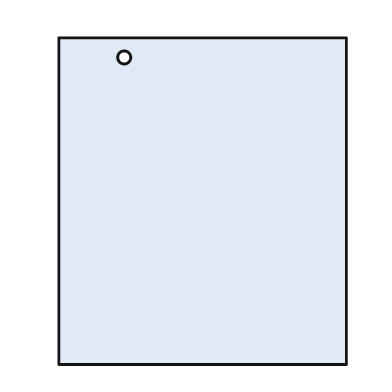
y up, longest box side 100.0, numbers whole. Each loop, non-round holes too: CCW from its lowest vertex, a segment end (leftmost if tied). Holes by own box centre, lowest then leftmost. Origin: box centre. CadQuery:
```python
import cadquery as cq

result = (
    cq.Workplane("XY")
    .moveTo(-44.0, -50.0)
    .lineTo(44.0, -50.0)
    .lineTo(44.0, 50.0)
    .lineTo(-44.0, 50.0)
    .close()
    .moveTo(-24.0, 44.0)
    .circle(2.0)
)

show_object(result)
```